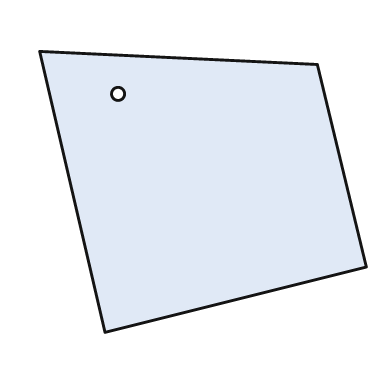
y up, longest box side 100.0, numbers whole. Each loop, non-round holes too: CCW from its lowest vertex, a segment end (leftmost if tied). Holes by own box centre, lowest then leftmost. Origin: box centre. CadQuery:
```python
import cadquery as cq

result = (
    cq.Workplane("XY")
    .moveTo(-30.0, -43.0)
    .lineTo(50.0, -23.0)
    .lineTo(35.0, 39.0)
    .lineTo(-50.0, 43.0)
    .close()
    .moveTo(-26.0, 30.0)
    .circle(2.0)
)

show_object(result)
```